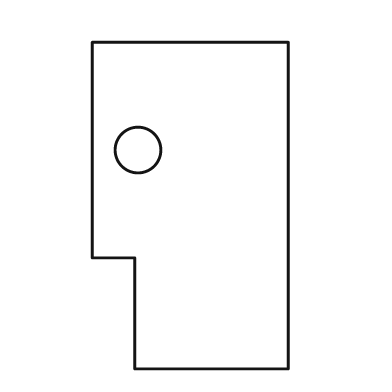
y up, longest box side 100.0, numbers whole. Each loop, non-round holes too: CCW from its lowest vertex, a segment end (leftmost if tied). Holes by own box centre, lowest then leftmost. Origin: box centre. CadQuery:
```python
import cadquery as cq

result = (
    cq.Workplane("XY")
    .moveTo(-17.0, -50.0)
    .lineTo(30.0, -50.0)
    .lineTo(30.0, 50.0)
    .lineTo(-30.0, 50.0)
    .lineTo(-30.0, -16.0)
    .lineTo(-17.0, -16.0)
    .close()
    .moveTo(-16.0, 17.0)
    .circle(7.0)
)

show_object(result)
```